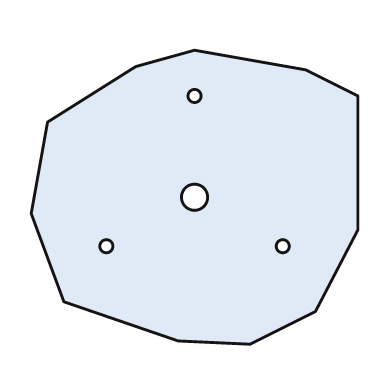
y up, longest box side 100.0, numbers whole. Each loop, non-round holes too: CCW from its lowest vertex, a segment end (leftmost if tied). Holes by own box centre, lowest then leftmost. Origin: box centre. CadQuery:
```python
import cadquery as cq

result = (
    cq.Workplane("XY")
    .moveTo(17.0, -45.0)
    .lineTo(37.0, -35.0)
    .lineTo(50.0, -10.0)
    .lineTo(50.0, 31.0)
    .lineTo(34.0, 39.0)
    .lineTo(0.0, 45.0)
    .lineTo(-18.0, 40.0)
    .lineTo(-45.0, 23.0)
    .lineTo(-50.0, -5.0)
    .lineTo(-40.0, -32.0)
    .lineTo(-5.0, -44.0)
    .close()
    .moveTo(-27.0, -15.0)
    .circle(2.0)
    .moveTo(27.0, -15.0)
    .circle(2.0)
    .moveTo(0.0, 0.0)
    .circle(4.0)
    .moveTo(0.0, 31.0)
    .circle(2.0)
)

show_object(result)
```